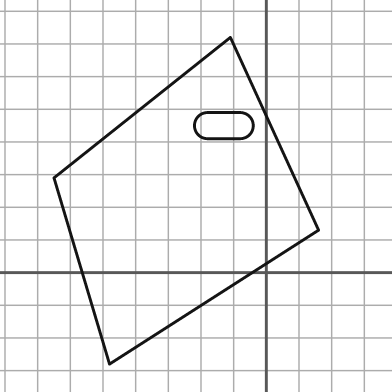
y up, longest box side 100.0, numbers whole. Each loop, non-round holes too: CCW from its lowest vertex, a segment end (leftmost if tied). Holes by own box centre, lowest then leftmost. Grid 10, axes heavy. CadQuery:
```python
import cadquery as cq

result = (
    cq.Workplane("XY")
    .moveTo(-48.0, -28.0)
    .lineTo(16.0, 13.0)
    .lineTo(-11.0, 72.0)
    .lineTo(-65.0, 29.0)
    .close()
    .moveTo(-18.0, 41.0)
    .lineTo(-8.0, 41.0)
    .threePointArc((-4.0, 45.0), (-8.0, 49.0))
    .lineTo(-18.0, 49.0)
    .threePointArc((-22.0, 45.0), (-18.0, 41.0))
    .close()
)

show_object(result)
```